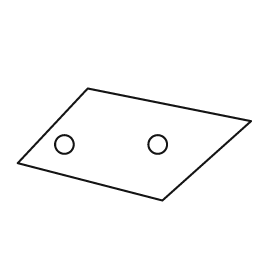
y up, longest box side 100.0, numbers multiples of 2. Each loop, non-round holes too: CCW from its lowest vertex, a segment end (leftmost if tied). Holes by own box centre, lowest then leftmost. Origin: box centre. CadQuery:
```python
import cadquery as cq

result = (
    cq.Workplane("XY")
    .moveTo(12.0, -24.0)
    .lineTo(50.0, 10.0)
    .lineTo(-20.0, 24.0)
    .lineTo(-50.0, -8.0)
    .close()
    .moveTo(-30.0, 0.0)
    .circle(4.0)
    .moveTo(10.0, 0.0)
    .circle(4.0)
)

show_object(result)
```